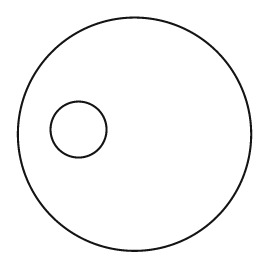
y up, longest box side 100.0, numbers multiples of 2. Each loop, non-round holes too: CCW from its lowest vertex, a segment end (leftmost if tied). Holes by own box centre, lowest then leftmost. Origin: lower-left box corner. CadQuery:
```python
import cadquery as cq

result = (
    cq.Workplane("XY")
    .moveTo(50.0, 50.0)
    .circle(50.0)
    .moveTo(26.0, 52.0)
    .circle(12.0)
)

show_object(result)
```